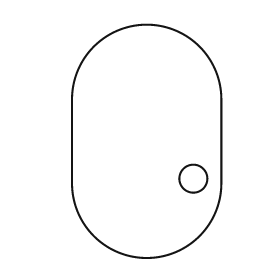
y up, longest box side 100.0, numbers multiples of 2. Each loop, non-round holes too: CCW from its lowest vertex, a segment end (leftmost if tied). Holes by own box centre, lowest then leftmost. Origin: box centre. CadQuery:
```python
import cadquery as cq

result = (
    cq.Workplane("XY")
    .moveTo(-32.0, -18.0)
    .threePointArc((0.0, -50.0), (32.0, -18.0))
    .lineTo(32.0, 18.0)
    .threePointArc((0.0, 50.0), (-32.0, 18.0))
    .close()
    .moveTo(20.0, -16.0)
    .circle(6.0)
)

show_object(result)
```